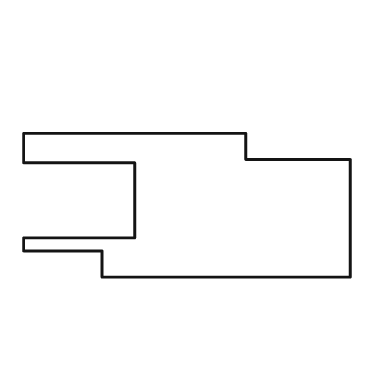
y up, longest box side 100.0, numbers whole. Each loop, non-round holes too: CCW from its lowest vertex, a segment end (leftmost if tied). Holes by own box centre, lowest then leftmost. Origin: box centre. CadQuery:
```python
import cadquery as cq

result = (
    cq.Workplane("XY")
    .moveTo(-26.0, -22.0)
    .lineTo(50.0, -22.0)
    .lineTo(50.0, 14.0)
    .lineTo(18.0, 14.0)
    .lineTo(18.0, 22.0)
    .lineTo(-50.0, 22.0)
    .lineTo(-50.0, 13.0)
    .lineTo(-16.0, 13.0)
    .lineTo(-16.0, -10.0)
    .lineTo(-50.0, -10.0)
    .lineTo(-50.0, -14.0)
    .lineTo(-26.0, -14.0)
    .close()
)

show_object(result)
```